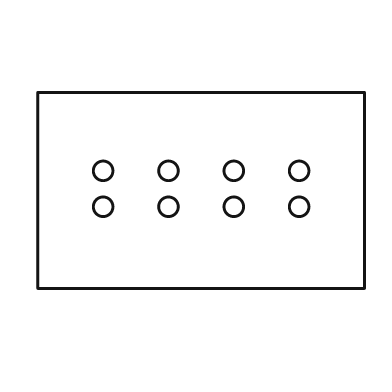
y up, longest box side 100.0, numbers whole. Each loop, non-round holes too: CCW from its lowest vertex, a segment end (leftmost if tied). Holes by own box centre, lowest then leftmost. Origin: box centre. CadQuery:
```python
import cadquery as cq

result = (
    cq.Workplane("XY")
    .moveTo(-50.0, -30.0)
    .lineTo(50.0, -30.0)
    .lineTo(50.0, 30.0)
    .lineTo(-50.0, 30.0)
    .close()
    .moveTo(-30.0, -5.0)
    .circle(3.0)
    .moveTo(-10.0, -5.0)
    .circle(3.0)
    .moveTo(10.0, -5.0)
    .circle(3.0)
    .moveTo(30.0, -5.0)
    .circle(3.0)
    .moveTo(-30.0, 6.0)
    .circle(3.0)
    .moveTo(-10.0, 6.0)
    .circle(3.0)
    .moveTo(10.0, 6.0)
    .circle(3.0)
    .moveTo(30.0, 6.0)
    .circle(3.0)
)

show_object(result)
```